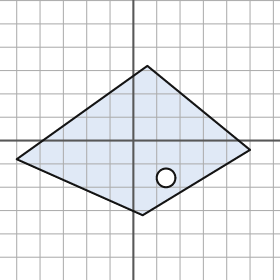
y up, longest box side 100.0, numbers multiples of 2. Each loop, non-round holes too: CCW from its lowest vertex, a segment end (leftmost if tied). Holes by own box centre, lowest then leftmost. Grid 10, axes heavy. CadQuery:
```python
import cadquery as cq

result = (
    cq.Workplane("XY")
    .moveTo(4.0, -32.0)
    .lineTo(50.0, -4.0)
    .lineTo(6.0, 32.0)
    .lineTo(-50.0, -8.0)
    .close()
    .moveTo(14.0, -16.0)
    .circle(4.0)
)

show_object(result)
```